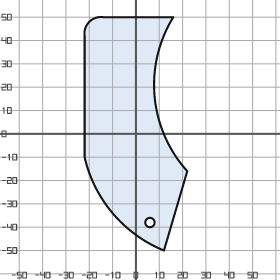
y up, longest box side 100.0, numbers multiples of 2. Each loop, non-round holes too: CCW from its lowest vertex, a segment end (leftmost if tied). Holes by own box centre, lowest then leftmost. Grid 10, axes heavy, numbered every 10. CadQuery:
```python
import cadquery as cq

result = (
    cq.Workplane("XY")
    .moveTo(12.0, -50.0)
    .lineTo(22.0, -16.0)
    .threePointArc((8.0, 16.0), (16.0, 50.0))
    .lineTo(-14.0, 50.0)
    .threePointArc((-20.0, 48.0), (-22.0, 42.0))
    .lineTo(-22.0, -10.0)
    .threePointArc((-10.0, -34.0), (12.0, -50.0))
    .close()
    .moveTo(6.0, -38.0)
    .circle(2.0)
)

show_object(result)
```